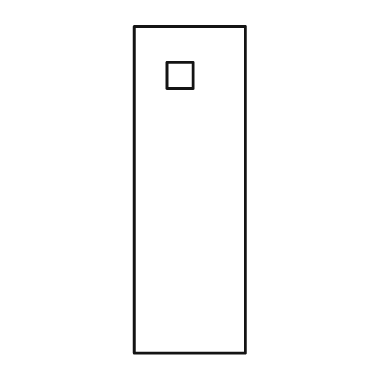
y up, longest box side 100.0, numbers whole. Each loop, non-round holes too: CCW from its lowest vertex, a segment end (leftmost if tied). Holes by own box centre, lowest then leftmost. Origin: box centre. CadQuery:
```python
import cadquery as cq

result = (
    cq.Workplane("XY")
    .moveTo(-17.0, -50.0)
    .lineTo(17.0, -50.0)
    .lineTo(17.0, 50.0)
    .lineTo(-17.0, 50.0)
    .close()
    .moveTo(-7.0, 31.0)
    .lineTo(1.0, 31.0)
    .lineTo(1.0, 39.0)
    .lineTo(-7.0, 39.0)
    .close()
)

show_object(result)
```